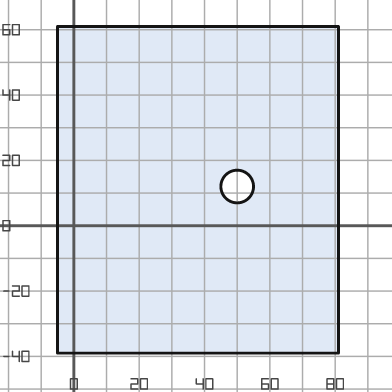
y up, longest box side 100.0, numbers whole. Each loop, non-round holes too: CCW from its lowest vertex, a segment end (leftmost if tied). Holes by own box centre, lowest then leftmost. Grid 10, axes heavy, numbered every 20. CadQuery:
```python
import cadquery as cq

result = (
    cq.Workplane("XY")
    .moveTo(-5.0, -39.0)
    .lineTo(81.0, -39.0)
    .lineTo(81.0, 61.0)
    .lineTo(-5.0, 61.0)
    .close()
    .moveTo(50.0, 12.0)
    .circle(5.0)
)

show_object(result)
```